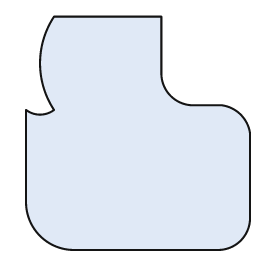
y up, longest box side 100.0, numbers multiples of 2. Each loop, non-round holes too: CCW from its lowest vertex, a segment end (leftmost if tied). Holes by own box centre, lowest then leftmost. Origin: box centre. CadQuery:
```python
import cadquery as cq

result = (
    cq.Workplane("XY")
    .moveTo(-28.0, -50.0)
    .lineTo(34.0, -50.0)
    .threePointArc((44.0, -46.0), (48.0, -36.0))
    .lineTo(48.0, 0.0)
    .threePointArc((44.0, 8.0), (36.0, 12.0))
    .lineTo(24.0, 12.0)
    .threePointArc((14.0, 16.0), (10.0, 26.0))
    .lineTo(10.0, 50.0)
    .lineTo(-36.0, 50.0)
    .threePointArc((-42.0, 30.0), (-36.0, 10.0))
    .threePointArc((-42.0, 8.0), (-48.0, 10.0))
    .lineTo(-48.0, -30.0)
    .threePointArc((-42.0, -44.0), (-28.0, -50.0))
    .close()
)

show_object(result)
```